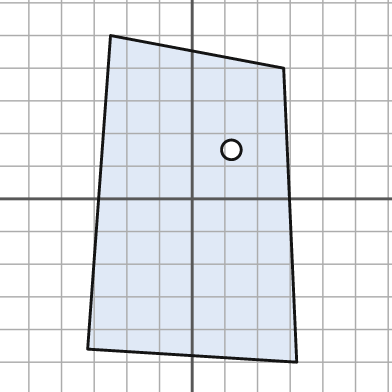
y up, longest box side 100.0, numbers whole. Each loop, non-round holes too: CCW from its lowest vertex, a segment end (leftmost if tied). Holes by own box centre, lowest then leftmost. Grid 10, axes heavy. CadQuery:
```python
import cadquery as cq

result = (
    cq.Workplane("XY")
    .moveTo(32.0, -50.0)
    .lineTo(28.0, 40.0)
    .lineTo(-25.0, 50.0)
    .lineTo(-32.0, -46.0)
    .close()
    .moveTo(12.0, 15.0)
    .circle(3.0)
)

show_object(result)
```